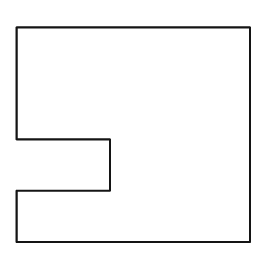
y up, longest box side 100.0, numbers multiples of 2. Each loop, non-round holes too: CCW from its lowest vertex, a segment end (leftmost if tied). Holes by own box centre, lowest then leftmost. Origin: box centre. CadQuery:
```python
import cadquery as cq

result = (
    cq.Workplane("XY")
    .moveTo(-50.0, -46.0)
    .lineTo(50.0, -46.0)
    .lineTo(50.0, 46.0)
    .lineTo(-50.0, 46.0)
    .lineTo(-50.0, -2.0)
    .lineTo(-10.0, -2.0)
    .lineTo(-10.0, -24.0)
    .lineTo(-50.0, -24.0)
    .close()
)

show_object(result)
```